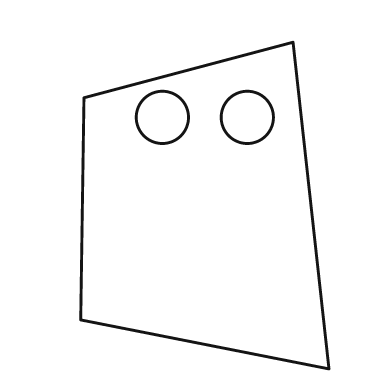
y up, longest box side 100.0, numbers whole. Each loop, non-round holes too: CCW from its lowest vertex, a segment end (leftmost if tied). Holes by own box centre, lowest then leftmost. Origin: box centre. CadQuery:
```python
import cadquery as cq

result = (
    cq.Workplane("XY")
    .moveTo(38.0, -50.0)
    .lineTo(27.0, 50.0)
    .lineTo(-37.0, 33.0)
    .lineTo(-38.0, -35.0)
    .close()
    .moveTo(-13.0, 27.0)
    .circle(8.0)
    .moveTo(13.0, 27.0)
    .circle(8.0)
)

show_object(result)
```